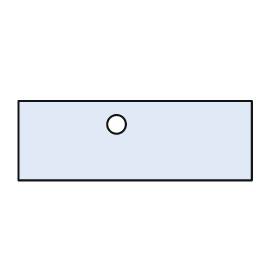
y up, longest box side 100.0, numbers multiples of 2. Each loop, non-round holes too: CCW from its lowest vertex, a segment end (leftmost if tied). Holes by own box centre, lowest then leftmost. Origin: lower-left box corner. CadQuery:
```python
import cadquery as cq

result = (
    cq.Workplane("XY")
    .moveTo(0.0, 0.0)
    .lineTo(100.0, 0.0)
    .lineTo(100.0, 34.0)
    .lineTo(0.0, 34.0)
    .close()
    .moveTo(42.0, 24.0)
    .circle(4.0)
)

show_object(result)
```